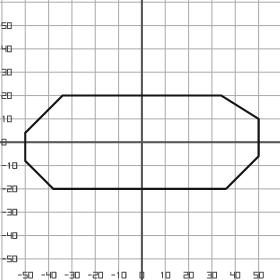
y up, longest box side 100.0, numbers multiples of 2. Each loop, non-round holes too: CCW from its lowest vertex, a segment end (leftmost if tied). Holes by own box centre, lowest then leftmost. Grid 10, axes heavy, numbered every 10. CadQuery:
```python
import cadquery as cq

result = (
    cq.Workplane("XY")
    .moveTo(-38.0, -20.0)
    .lineTo(36.0, -20.0)
    .lineTo(50.0, -6.0)
    .lineTo(50.0, 10.0)
    .lineTo(34.0, 20.0)
    .lineTo(-34.0, 20.0)
    .lineTo(-50.0, 4.0)
    .lineTo(-50.0, -8.0)
    .close()
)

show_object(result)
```